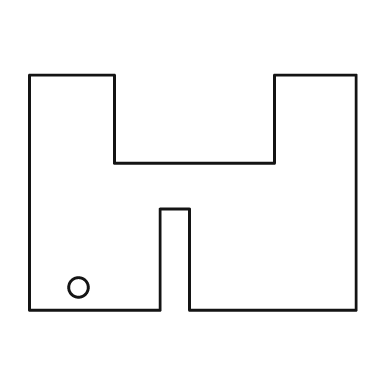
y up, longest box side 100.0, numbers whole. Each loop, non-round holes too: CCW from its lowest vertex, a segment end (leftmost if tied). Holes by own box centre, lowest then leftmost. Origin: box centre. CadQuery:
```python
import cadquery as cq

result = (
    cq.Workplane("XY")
    .moveTo(-50.0, -36.0)
    .lineTo(-10.0, -36.0)
    .lineTo(-10.0, -5.0)
    .lineTo(-1.0, -5.0)
    .lineTo(-1.0, -36.0)
    .lineTo(50.0, -36.0)
    .lineTo(50.0, 36.0)
    .lineTo(25.0, 36.0)
    .lineTo(25.0, 9.0)
    .lineTo(-24.0, 9.0)
    .lineTo(-24.0, 36.0)
    .lineTo(-50.0, 36.0)
    .close()
    .moveTo(-35.0, -29.0)
    .circle(3.0)
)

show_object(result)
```